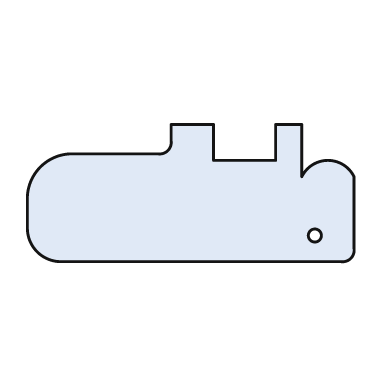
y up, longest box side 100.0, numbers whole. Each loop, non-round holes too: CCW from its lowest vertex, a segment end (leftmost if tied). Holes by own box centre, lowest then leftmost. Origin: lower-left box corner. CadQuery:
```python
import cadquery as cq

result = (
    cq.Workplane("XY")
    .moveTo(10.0, 0.0)
    .lineTo(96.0, 0.0)
    .threePointArc((99.0, 1.0), (100.0, 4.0))
    .lineTo(100.0, 26.0)
    .threePointArc((92.0, 31.0), (84.0, 26.0))
    .lineTo(84.0, 42.0)
    .lineTo(76.0, 42.0)
    .lineTo(76.0, 31.0)
    .lineTo(57.0, 31.0)
    .lineTo(57.0, 42.0)
    .lineTo(44.0, 42.0)
    .lineTo(44.0, 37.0)
    .threePointArc((43.0, 34.0), (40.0, 33.0))
    .lineTo(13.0, 33.0)
    .threePointArc((4.0, 29.0), (0.0, 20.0))
    .lineTo(0.0, 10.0)
    .threePointArc((3.0, 3.0), (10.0, 0.0))
    .close()
    .moveTo(88.0, 8.0)
    .circle(2.0)
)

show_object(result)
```